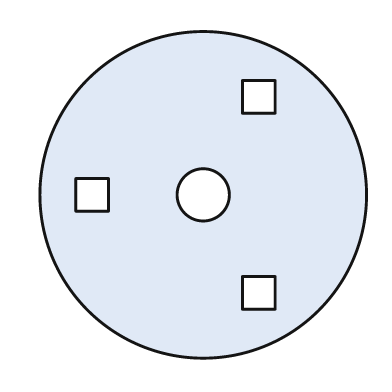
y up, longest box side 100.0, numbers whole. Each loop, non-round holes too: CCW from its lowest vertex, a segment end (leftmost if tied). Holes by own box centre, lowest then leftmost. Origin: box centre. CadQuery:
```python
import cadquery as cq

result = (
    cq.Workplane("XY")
    .moveTo(0.0, 0.0)
    .circle(50.0)
    .moveTo(12.0, -35.0)
    .lineTo(22.0, -35.0)
    .lineTo(22.0, -25.0)
    .lineTo(12.0, -25.0)
    .close()
    .moveTo(-39.0, -5.0)
    .lineTo(-29.0, -5.0)
    .lineTo(-29.0, 5.0)
    .lineTo(-39.0, 5.0)
    .close()
    .moveTo(0.0, 0.0)
    .circle(8.0)
    .moveTo(12.0, 25.0)
    .lineTo(22.0, 25.0)
    .lineTo(22.0, 35.0)
    .lineTo(12.0, 35.0)
    .close()
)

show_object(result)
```